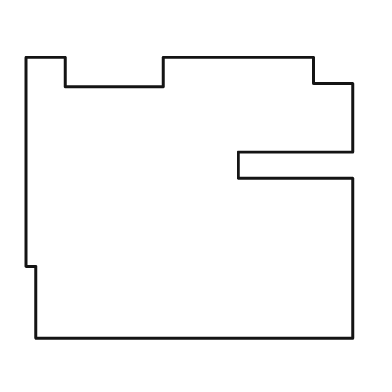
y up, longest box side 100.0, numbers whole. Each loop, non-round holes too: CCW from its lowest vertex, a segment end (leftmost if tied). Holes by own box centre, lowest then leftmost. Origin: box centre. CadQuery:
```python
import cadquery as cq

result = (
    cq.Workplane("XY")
    .moveTo(-47.0, -43.0)
    .lineTo(50.0, -43.0)
    .lineTo(50.0, 6.0)
    .lineTo(15.0, 6.0)
    .lineTo(15.0, 14.0)
    .lineTo(50.0, 14.0)
    .lineTo(50.0, 35.0)
    .lineTo(38.0, 35.0)
    .lineTo(38.0, 43.0)
    .lineTo(-8.0, 43.0)
    .lineTo(-8.0, 34.0)
    .lineTo(-38.0, 34.0)
    .lineTo(-38.0, 43.0)
    .lineTo(-50.0, 43.0)
    .lineTo(-50.0, -21.0)
    .lineTo(-47.0, -21.0)
    .close()
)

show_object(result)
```